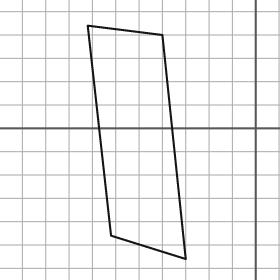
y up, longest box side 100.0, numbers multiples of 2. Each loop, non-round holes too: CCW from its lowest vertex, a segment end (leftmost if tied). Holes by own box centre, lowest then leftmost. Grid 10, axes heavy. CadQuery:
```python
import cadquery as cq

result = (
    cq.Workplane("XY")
    .moveTo(-30.0, -56.0)
    .lineTo(-40.0, 40.0)
    .lineTo(-72.0, 44.0)
    .lineTo(-62.0, -46.0)
    .close()
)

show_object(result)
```